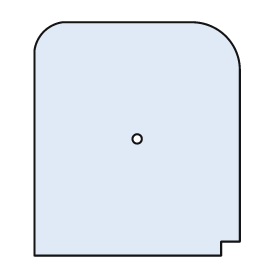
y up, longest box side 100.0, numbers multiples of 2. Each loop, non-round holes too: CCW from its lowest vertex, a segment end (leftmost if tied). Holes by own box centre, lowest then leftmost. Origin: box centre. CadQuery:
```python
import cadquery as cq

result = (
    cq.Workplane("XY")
    .moveTo(-44.0, -50.0)
    .lineTo(36.0, -50.0)
    .lineTo(36.0, -44.0)
    .lineTo(44.0, -44.0)
    .lineTo(44.0, 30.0)
    .threePointArc((38.0, 44.0), (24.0, 50.0))
    .lineTo(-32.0, 50.0)
    .threePointArc((-40.0, 46.0), (-44.0, 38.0))
    .close()
    .moveTo(0.0, 0.0)
    .circle(2.0)
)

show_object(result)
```